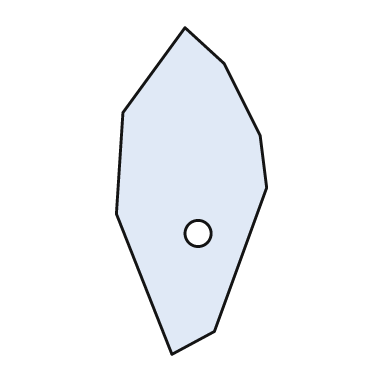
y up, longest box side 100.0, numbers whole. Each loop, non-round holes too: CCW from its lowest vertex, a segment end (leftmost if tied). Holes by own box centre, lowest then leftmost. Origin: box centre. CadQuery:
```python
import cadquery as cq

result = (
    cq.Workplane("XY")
    .moveTo(-6.0, -50.0)
    .lineTo(7.0, -43.0)
    .lineTo(23.0, 1.0)
    .lineTo(21.0, 17.0)
    .lineTo(10.0, 39.0)
    .lineTo(-2.0, 50.0)
    .lineTo(-21.0, 24.0)
    .lineTo(-23.0, -7.0)
    .close()
    .moveTo(2.0, -13.0)
    .circle(4.0)
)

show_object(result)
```